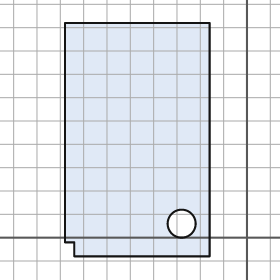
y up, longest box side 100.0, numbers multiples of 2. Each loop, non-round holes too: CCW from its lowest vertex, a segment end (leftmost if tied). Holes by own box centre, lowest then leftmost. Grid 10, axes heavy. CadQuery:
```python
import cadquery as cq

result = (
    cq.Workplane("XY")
    .moveTo(-74.0, -8.0)
    .lineTo(-16.0, -8.0)
    .lineTo(-16.0, 92.0)
    .lineTo(-78.0, 92.0)
    .lineTo(-78.0, -2.0)
    .lineTo(-74.0, -2.0)
    .close()
    .moveTo(-28.0, 6.0)
    .circle(6.0)
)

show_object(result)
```